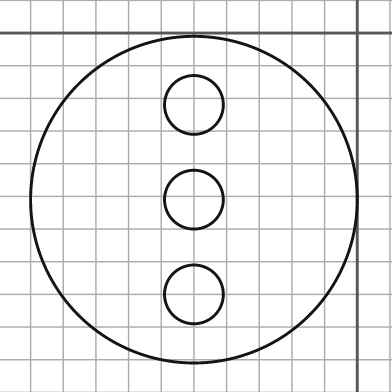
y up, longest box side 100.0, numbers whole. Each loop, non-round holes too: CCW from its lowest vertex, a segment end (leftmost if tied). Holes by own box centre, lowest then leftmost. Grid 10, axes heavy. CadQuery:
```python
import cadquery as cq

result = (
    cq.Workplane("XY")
    .moveTo(-50.0, -51.0)
    .circle(50.0)
    .moveTo(-50.0, -80.0)
    .circle(9.0)
    .moveTo(-50.0, -51.0)
    .circle(9.0)
    .moveTo(-50.0, -22.0)
    .circle(9.0)
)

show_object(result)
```